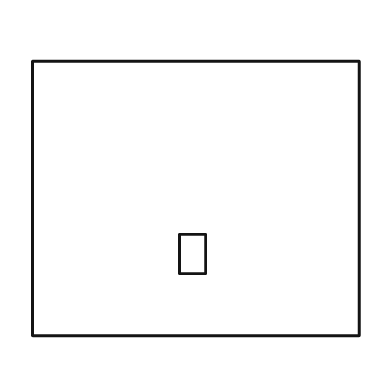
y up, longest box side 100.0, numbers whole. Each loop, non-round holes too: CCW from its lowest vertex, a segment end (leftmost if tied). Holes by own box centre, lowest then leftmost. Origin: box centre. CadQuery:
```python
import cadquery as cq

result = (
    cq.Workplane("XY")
    .moveTo(-50.0, -42.0)
    .lineTo(50.0, -42.0)
    .lineTo(50.0, 42.0)
    .lineTo(-50.0, 42.0)
    .close()
    .moveTo(-5.0, -23.0)
    .lineTo(3.0, -23.0)
    .lineTo(3.0, -11.0)
    .lineTo(-5.0, -11.0)
    .close()
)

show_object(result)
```